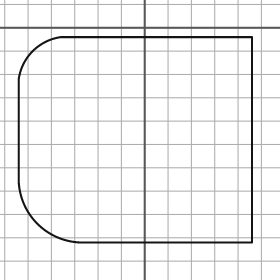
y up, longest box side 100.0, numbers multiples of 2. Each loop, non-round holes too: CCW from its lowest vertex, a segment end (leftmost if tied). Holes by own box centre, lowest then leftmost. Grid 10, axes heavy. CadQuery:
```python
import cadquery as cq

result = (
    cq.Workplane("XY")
    .moveTo(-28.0, -92.0)
    .lineTo(46.0, -92.0)
    .lineTo(46.0, -4.0)
    .lineTo(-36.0, -4.0)
    .threePointArc((-48.0, -10.0), (-54.0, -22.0))
    .lineTo(-54.0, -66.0)
    .threePointArc((-46.0, -84.0), (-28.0, -92.0))
    .close()
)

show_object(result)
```